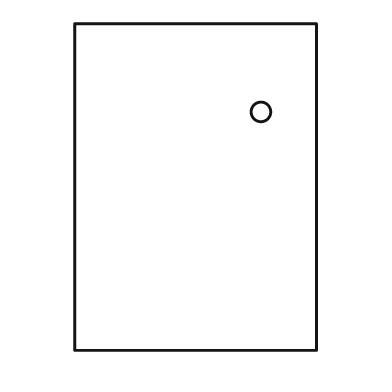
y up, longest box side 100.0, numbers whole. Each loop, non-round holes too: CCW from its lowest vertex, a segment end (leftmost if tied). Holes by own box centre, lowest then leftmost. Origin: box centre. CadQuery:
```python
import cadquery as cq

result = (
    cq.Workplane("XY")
    .moveTo(-37.0, -50.0)
    .lineTo(37.0, -50.0)
    .lineTo(37.0, 50.0)
    .lineTo(-37.0, 50.0)
    .close()
    .moveTo(20.0, 23.0)
    .circle(3.0)
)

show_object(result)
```